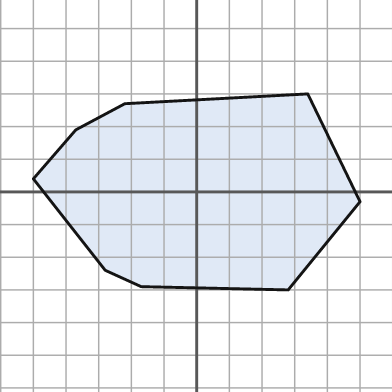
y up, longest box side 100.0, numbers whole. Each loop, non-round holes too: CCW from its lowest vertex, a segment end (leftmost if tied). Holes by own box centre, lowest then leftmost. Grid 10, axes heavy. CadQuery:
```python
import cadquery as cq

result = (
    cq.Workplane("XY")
    .moveTo(28.0, -30.0)
    .lineTo(50.0, -3.0)
    .lineTo(34.0, 30.0)
    .lineTo(-22.0, 27.0)
    .lineTo(-37.0, 19.0)
    .lineTo(-50.0, 4.0)
    .lineTo(-28.0, -24.0)
    .lineTo(-17.0, -29.0)
    .close()
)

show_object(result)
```